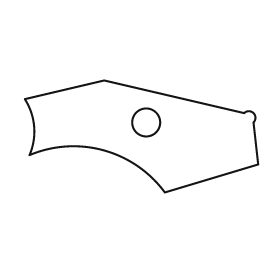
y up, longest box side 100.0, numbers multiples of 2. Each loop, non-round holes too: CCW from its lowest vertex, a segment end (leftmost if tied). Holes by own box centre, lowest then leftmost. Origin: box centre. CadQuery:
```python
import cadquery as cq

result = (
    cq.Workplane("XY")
    .moveTo(10.0, -24.0)
    .lineTo(50.0, -12.0)
    .lineTo(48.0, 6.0)
    .threePointArc((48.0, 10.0), (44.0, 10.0))
    .lineTo(-16.0, 24.0)
    .lineTo(-50.0, 16.0)
    .threePointArc((-46.0, 4.0), (-48.0, -8.0))
    .threePointArc((-16.0, -6.0), (10.0, -24.0))
    .close()
    .moveTo(2.0, 6.0)
    .circle(6.0)
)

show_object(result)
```